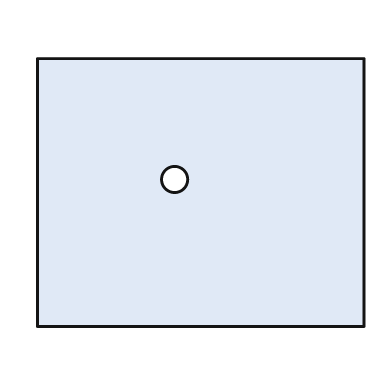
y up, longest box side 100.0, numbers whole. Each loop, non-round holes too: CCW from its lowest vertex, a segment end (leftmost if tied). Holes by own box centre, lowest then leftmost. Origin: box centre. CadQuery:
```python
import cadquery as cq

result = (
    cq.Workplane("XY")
    .moveTo(-50.0, -41.0)
    .lineTo(50.0, -41.0)
    .lineTo(50.0, 41.0)
    .lineTo(-50.0, 41.0)
    .close()
    .moveTo(-8.0, 4.0)
    .circle(4.0)
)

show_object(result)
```